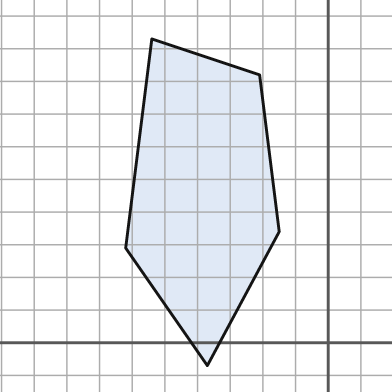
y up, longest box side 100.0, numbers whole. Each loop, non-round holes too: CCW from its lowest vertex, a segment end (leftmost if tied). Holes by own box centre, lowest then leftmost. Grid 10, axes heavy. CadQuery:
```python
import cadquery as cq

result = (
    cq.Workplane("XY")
    .moveTo(-37.0, -7.0)
    .lineTo(-15.0, 34.0)
    .lineTo(-21.0, 82.0)
    .lineTo(-54.0, 93.0)
    .lineTo(-62.0, 29.0)
    .close()
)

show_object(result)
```